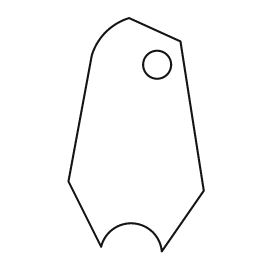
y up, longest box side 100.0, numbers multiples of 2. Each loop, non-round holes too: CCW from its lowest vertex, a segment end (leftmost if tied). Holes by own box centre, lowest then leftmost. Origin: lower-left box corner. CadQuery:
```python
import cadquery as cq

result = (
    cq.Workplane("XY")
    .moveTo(40.0, 0.0)
    .lineTo(58.0, 26.0)
    .lineTo(48.0, 90.0)
    .lineTo(26.0, 100.0)
    .threePointArc((16.0, 94.0), (10.0, 84.0))
    .lineTo(0.0, 30.0)
    .lineTo(14.0, 2.0)
    .threePointArc((28.0, 12.0), (40.0, 0.0))
    .close()
    .moveTo(38.0, 80.0)
    .circle(6.0)
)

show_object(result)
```